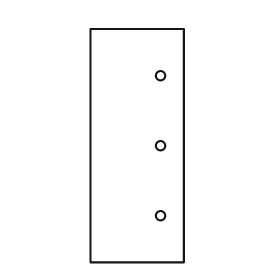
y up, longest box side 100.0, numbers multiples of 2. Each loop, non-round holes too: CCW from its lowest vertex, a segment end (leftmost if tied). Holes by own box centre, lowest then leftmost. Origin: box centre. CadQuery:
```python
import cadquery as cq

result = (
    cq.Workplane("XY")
    .moveTo(-20.0, -50.0)
    .lineTo(20.0, -50.0)
    .lineTo(20.0, 50.0)
    .lineTo(-20.0, 50.0)
    .close()
    .moveTo(10.0, -30.0)
    .circle(2.0)
    .moveTo(10.0, 0.0)
    .circle(2.0)
    .moveTo(10.0, 30.0)
    .circle(2.0)
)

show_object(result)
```